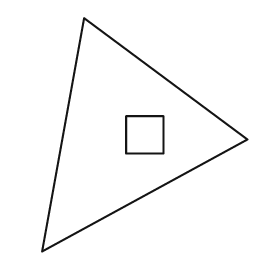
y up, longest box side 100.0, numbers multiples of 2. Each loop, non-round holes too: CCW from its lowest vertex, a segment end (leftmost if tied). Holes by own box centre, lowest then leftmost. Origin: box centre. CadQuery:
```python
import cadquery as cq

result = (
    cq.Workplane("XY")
    .moveTo(-44.0, -50.0)
    .lineTo(44.0, -2.0)
    .lineTo(-26.0, 50.0)
    .close()
    .moveTo(-8.0, -8.0)
    .lineTo(8.0, -8.0)
    .lineTo(8.0, 8.0)
    .lineTo(-8.0, 8.0)
    .close()
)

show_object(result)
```